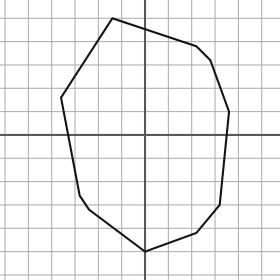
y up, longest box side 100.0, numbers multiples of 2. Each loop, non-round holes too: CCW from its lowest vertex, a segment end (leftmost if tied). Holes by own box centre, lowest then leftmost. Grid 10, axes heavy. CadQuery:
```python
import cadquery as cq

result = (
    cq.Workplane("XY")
    .moveTo(0.0, -50.0)
    .lineTo(22.0, -42.0)
    .lineTo(32.0, -30.0)
    .lineTo(36.0, 10.0)
    .lineTo(28.0, 32.0)
    .lineTo(22.0, 38.0)
    .lineTo(-14.0, 50.0)
    .lineTo(-36.0, 16.0)
    .lineTo(-28.0, -26.0)
    .lineTo(-24.0, -32.0)
    .close()
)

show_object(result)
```